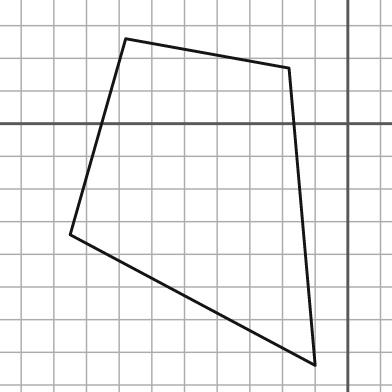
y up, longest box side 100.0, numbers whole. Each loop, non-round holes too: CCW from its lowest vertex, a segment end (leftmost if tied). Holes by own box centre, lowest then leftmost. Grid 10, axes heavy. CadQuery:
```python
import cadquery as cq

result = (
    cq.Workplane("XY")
    .moveTo(-10.0, -74.0)
    .lineTo(-18.0, 17.0)
    .lineTo(-68.0, 26.0)
    .lineTo(-85.0, -34.0)
    .close()
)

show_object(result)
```